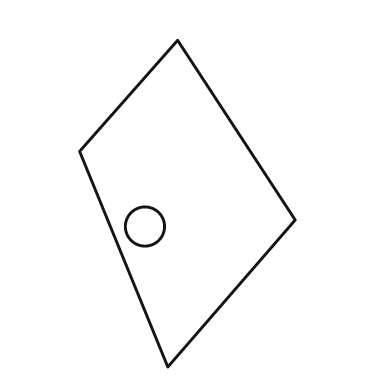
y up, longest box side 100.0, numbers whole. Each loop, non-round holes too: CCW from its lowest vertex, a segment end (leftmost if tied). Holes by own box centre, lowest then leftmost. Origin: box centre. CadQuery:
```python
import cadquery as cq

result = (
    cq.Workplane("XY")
    .moveTo(-6.0, -50.0)
    .lineTo(33.0, -5.0)
    .lineTo(-3.0, 50.0)
    .lineTo(-33.0, 16.0)
    .close()
    .moveTo(-13.0, -7.0)
    .circle(6.0)
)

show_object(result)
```